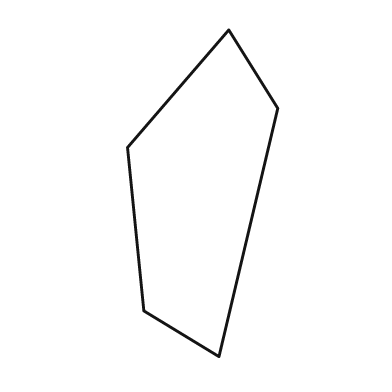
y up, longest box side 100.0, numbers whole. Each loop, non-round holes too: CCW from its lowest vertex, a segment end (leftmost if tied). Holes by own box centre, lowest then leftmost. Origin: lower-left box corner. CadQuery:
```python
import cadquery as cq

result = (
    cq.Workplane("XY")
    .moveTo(28.0, 0.0)
    .lineTo(46.0, 76.0)
    .lineTo(31.0, 100.0)
    .lineTo(0.0, 64.0)
    .lineTo(5.0, 14.0)
    .close()
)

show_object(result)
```